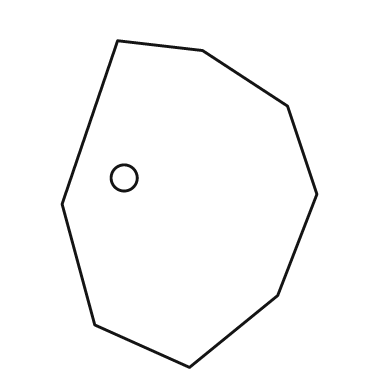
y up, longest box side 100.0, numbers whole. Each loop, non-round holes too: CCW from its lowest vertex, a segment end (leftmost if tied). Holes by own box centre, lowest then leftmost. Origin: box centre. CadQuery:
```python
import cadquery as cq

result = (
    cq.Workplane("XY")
    .moveTo(0.0, -50.0)
    .lineTo(27.0, -28.0)
    .lineTo(39.0, 3.0)
    .lineTo(30.0, 30.0)
    .lineTo(4.0, 47.0)
    .lineTo(-22.0, 50.0)
    .lineTo(-39.0, 0.0)
    .lineTo(-29.0, -37.0)
    .close()
    .moveTo(-20.0, 8.0)
    .circle(4.0)
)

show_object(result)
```